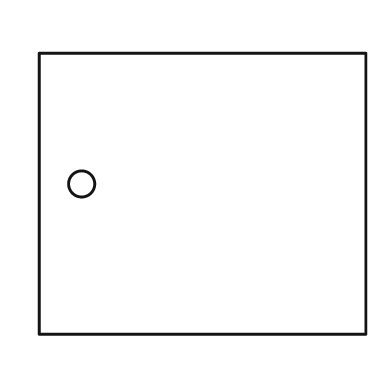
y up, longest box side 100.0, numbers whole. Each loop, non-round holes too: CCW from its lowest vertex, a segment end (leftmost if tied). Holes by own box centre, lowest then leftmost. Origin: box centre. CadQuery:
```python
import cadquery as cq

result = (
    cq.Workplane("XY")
    .moveTo(-50.0, -43.0)
    .lineTo(50.0, -43.0)
    .lineTo(50.0, 43.0)
    .lineTo(-50.0, 43.0)
    .close()
    .moveTo(-37.0, 3.0)
    .circle(4.0)
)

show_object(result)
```